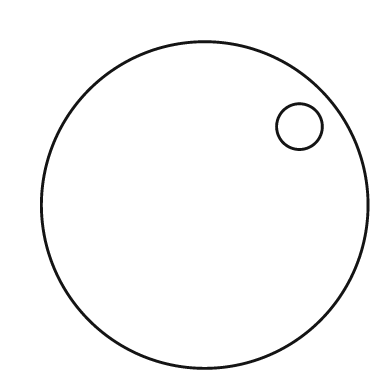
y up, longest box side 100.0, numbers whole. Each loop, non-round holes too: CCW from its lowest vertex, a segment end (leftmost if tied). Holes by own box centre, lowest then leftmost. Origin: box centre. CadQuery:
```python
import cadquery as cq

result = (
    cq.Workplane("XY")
    .moveTo(0.0, 0.0)
    .circle(50.0)
    .moveTo(29.0, 24.0)
    .circle(7.0)
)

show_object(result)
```